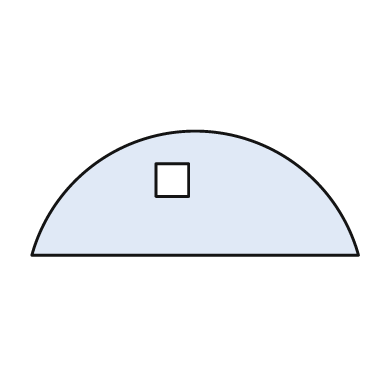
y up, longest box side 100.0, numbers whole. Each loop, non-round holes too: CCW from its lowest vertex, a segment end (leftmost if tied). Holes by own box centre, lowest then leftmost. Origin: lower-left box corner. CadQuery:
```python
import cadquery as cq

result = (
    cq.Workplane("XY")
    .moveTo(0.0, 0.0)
    .lineTo(100.0, 0.0)
    .threePointArc((50.0, 38.0), (0.0, 0.0))
    .close()
    .moveTo(38.0, 18.0)
    .lineTo(48.0, 18.0)
    .lineTo(48.0, 28.0)
    .lineTo(38.0, 28.0)
    .close()
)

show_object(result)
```